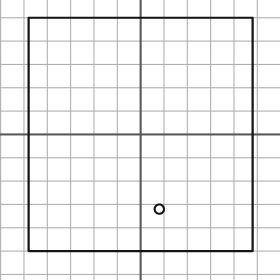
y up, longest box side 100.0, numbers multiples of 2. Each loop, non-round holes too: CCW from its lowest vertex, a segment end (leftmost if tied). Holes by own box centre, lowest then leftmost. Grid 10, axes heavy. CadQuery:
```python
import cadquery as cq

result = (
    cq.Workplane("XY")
    .moveTo(-48.0, -50.0)
    .lineTo(48.0, -50.0)
    .lineTo(48.0, 50.0)
    .lineTo(-48.0, 50.0)
    .close()
    .moveTo(8.0, -32.0)
    .circle(2.0)
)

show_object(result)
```